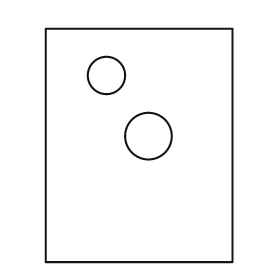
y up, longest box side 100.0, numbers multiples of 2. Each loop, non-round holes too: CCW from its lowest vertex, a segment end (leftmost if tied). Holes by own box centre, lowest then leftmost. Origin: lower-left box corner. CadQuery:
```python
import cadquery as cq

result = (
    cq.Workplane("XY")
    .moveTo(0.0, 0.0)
    .lineTo(80.0, 0.0)
    .lineTo(80.0, 100.0)
    .lineTo(0.0, 100.0)
    .close()
    .moveTo(44.0, 54.0)
    .circle(10.0)
    .moveTo(26.0, 80.0)
    .circle(8.0)
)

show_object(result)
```